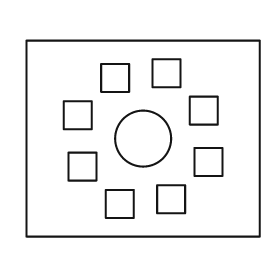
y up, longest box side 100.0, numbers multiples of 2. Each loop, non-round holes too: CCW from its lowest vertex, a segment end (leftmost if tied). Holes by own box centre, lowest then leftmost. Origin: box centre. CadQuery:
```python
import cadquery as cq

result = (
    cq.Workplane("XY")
    .moveTo(-50.0, -42.0)
    .lineTo(50.0, -42.0)
    .lineTo(50.0, 42.0)
    .lineTo(-50.0, 42.0)
    .close()
    .moveTo(-16.0, -34.0)
    .lineTo(-4.0, -34.0)
    .lineTo(-4.0, -22.0)
    .lineTo(-16.0, -22.0)
    .close()
    .moveTo(6.0, -32.0)
    .lineTo(18.0, -32.0)
    .lineTo(18.0, -20.0)
    .lineTo(6.0, -20.0)
    .close()
    .moveTo(-32.0, -18.0)
    .lineTo(-20.0, -18.0)
    .lineTo(-20.0, -6.0)
    .lineTo(-32.0, -6.0)
    .close()
    .moveTo(22.0, -16.0)
    .lineTo(34.0, -16.0)
    .lineTo(34.0, -4.0)
    .lineTo(22.0, -4.0)
    .close()
    .moveTo(0.0, 0.0)
    .circle(12.0)
    .moveTo(-34.0, 4.0)
    .lineTo(-22.0, 4.0)
    .lineTo(-22.0, 16.0)
    .lineTo(-34.0, 16.0)
    .close()
    .moveTo(20.0, 6.0)
    .lineTo(32.0, 6.0)
    .lineTo(32.0, 18.0)
    .lineTo(20.0, 18.0)
    .close()
    .moveTo(-18.0, 20.0)
    .lineTo(-6.0, 20.0)
    .lineTo(-6.0, 32.0)
    .lineTo(-18.0, 32.0)
    .close()
    .moveTo(4.0, 22.0)
    .lineTo(16.0, 22.0)
    .lineTo(16.0, 34.0)
    .lineTo(4.0, 34.0)
    .close()
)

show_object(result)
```